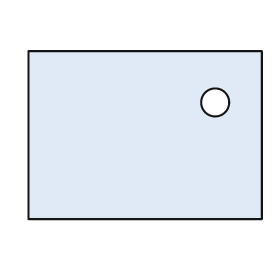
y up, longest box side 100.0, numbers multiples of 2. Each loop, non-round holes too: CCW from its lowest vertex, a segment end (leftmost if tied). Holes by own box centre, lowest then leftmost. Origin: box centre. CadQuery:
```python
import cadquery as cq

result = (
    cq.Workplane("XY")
    .moveTo(-50.0, -36.0)
    .lineTo(50.0, -36.0)
    .lineTo(50.0, 36.0)
    .lineTo(-50.0, 36.0)
    .close()
    .moveTo(30.0, 14.0)
    .circle(6.0)
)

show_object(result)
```